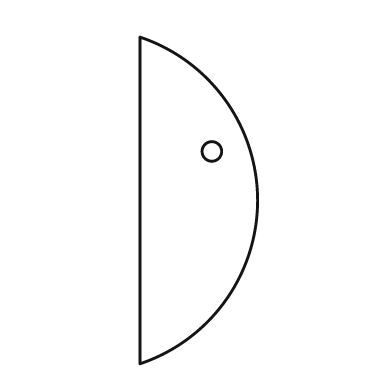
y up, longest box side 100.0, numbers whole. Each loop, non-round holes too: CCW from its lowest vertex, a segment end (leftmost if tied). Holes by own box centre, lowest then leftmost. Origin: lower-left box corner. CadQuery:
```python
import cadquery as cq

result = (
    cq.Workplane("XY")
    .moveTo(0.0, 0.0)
    .threePointArc((36.0, 50.0), (0.0, 100.0))
    .close()
    .moveTo(22.0, 65.0)
    .circle(3.0)
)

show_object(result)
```